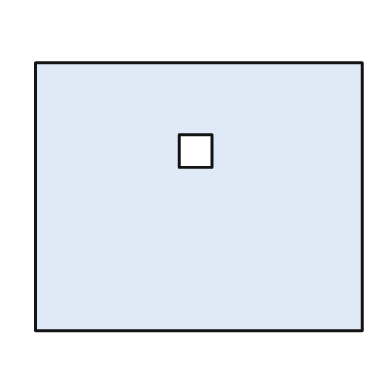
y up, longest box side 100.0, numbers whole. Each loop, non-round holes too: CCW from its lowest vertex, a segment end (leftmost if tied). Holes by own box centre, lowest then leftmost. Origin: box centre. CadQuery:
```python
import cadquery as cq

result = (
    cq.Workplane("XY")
    .moveTo(-50.0, -41.0)
    .lineTo(50.0, -41.0)
    .lineTo(50.0, 41.0)
    .lineTo(-50.0, 41.0)
    .close()
    .moveTo(-6.0, 9.0)
    .lineTo(4.0, 9.0)
    .lineTo(4.0, 19.0)
    .lineTo(-6.0, 19.0)
    .close()
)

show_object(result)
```